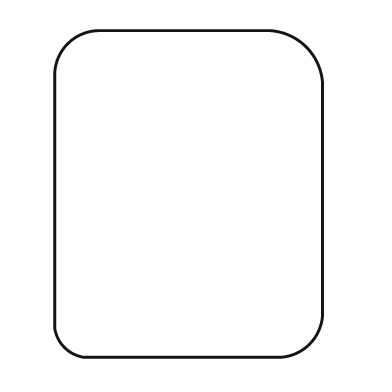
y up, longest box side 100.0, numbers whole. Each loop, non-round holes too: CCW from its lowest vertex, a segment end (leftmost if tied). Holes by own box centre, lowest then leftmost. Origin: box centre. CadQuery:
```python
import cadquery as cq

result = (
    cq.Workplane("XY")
    .moveTo(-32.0, -50.0)
    .lineTo(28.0, -50.0)
    .threePointArc((37.0, -46.0), (41.0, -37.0))
    .lineTo(41.0, 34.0)
    .threePointArc((36.0, 45.0), (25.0, 50.0))
    .lineTo(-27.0, 50.0)
    .threePointArc((-37.0, 46.0), (-41.0, 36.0))
    .lineTo(-41.0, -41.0)
    .threePointArc((-38.0, -47.0), (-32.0, -50.0))
    .close()
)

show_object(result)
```